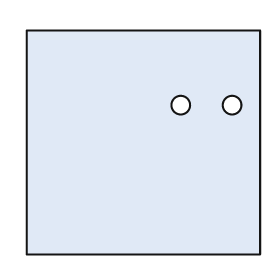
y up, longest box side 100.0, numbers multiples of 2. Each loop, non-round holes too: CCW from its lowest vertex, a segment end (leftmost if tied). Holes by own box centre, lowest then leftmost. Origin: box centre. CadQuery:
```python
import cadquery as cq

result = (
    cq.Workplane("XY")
    .moveTo(-50.0, -48.0)
    .lineTo(50.0, -48.0)
    .lineTo(50.0, 48.0)
    .lineTo(-50.0, 48.0)
    .close()
    .moveTo(16.0, 16.0)
    .circle(4.0)
    .moveTo(38.0, 16.0)
    .circle(4.0)
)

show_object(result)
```